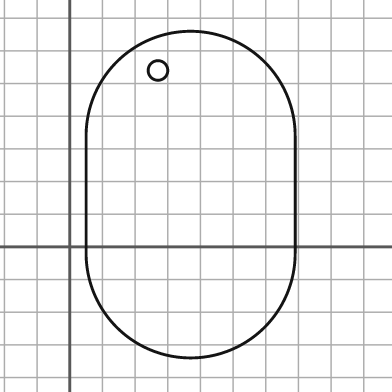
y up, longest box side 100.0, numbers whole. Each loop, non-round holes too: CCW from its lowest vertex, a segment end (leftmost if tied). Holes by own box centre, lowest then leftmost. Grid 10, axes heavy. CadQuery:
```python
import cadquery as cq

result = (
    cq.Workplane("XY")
    .moveTo(5.0, -2.0)
    .threePointArc((37.0, -34.0), (69.0, -2.0))
    .lineTo(69.0, 34.0)
    .threePointArc((37.0, 66.0), (5.0, 34.0))
    .close()
    .moveTo(27.0, 54.0)
    .circle(3.0)
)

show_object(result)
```